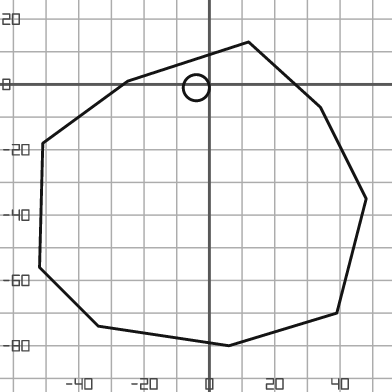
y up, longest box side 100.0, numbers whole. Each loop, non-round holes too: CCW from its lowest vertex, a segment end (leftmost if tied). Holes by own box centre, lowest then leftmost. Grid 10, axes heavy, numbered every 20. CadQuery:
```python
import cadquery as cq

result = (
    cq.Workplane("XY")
    .moveTo(6.0, -80.0)
    .lineTo(39.0, -70.0)
    .lineTo(48.0, -35.0)
    .lineTo(34.0, -7.0)
    .lineTo(12.0, 13.0)
    .lineTo(-25.0, 1.0)
    .lineTo(-51.0, -18.0)
    .lineTo(-52.0, -56.0)
    .lineTo(-34.0, -74.0)
    .close()
    .moveTo(-4.0, -1.0)
    .circle(4.0)
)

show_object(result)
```